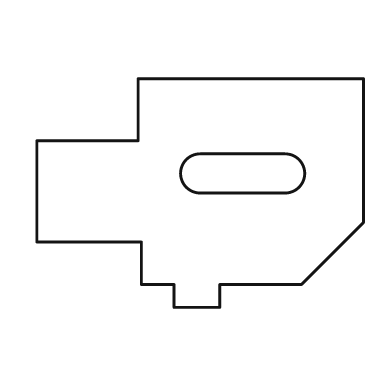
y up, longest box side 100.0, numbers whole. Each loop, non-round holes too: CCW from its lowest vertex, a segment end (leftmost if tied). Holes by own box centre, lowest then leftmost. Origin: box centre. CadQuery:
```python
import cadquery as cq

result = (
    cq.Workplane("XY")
    .moveTo(-8.0, -35.0)
    .lineTo(6.0, -35.0)
    .lineTo(6.0, -28.0)
    .lineTo(31.0, -28.0)
    .lineTo(50.0, -9.0)
    .lineTo(50.0, 35.0)
    .lineTo(-19.0, 35.0)
    .lineTo(-19.0, 16.0)
    .lineTo(-50.0, 16.0)
    .lineTo(-50.0, -15.0)
    .lineTo(-18.0, -15.0)
    .lineTo(-18.0, -28.0)
    .lineTo(-8.0, -28.0)
    .close()
    .moveTo(0.0, 0.0)
    .lineTo(26.0, 0.0)
    .threePointArc((32.0, 6.0), (26.0, 12.0))
    .lineTo(0.0, 12.0)
    .threePointArc((-6.0, 6.0), (0.0, 0.0))
    .close()
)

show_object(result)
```